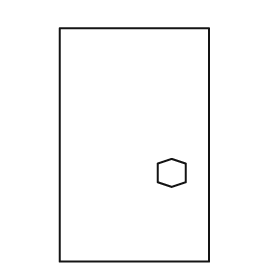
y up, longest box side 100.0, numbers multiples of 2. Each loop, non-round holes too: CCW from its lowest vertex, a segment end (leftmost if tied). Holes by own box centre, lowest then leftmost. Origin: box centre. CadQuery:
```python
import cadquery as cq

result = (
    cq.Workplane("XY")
    .moveTo(-32.0, -50.0)
    .lineTo(32.0, -50.0)
    .lineTo(32.0, 50.0)
    .lineTo(-32.0, 50.0)
    .close()
    .moveTo(16.0, -18.0)
    .lineTo(22.0, -16.0)
    .lineTo(22.0, -8.0)
    .lineTo(16.0, -6.0)
    .lineTo(10.0, -8.0)
    .lineTo(10.0, -16.0)
    .close()
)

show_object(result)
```